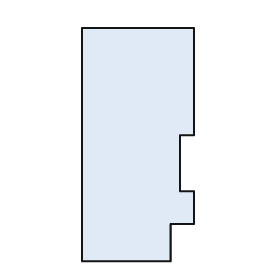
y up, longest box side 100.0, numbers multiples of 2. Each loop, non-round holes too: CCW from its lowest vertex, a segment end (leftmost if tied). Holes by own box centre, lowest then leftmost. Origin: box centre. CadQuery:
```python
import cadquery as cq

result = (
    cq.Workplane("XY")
    .moveTo(-24.0, -50.0)
    .lineTo(14.0, -50.0)
    .lineTo(14.0, -34.0)
    .lineTo(24.0, -34.0)
    .lineTo(24.0, -20.0)
    .lineTo(18.0, -20.0)
    .lineTo(18.0, 4.0)
    .lineTo(24.0, 4.0)
    .lineTo(24.0, 50.0)
    .lineTo(-24.0, 50.0)
    .close()
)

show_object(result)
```